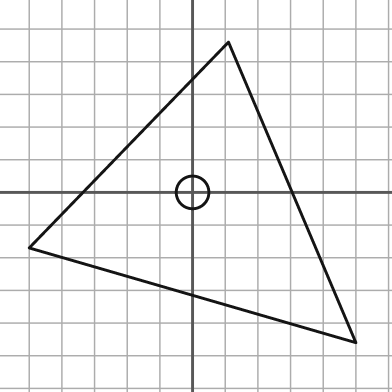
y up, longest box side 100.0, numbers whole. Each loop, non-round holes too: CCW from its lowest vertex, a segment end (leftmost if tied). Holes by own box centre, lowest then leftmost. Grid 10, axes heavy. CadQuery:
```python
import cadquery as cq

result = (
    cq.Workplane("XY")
    .moveTo(50.0, -46.0)
    .lineTo(11.0, 46.0)
    .lineTo(-50.0, -17.0)
    .close()
    .moveTo(0.0, 0.0)
    .circle(5.0)
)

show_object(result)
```